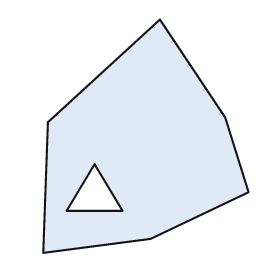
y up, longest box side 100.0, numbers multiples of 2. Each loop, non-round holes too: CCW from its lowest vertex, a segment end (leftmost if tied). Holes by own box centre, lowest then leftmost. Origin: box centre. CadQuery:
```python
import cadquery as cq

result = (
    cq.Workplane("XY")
    .moveTo(-44.0, -50.0)
    .lineTo(2.0, -44.0)
    .lineTo(44.0, -24.0)
    .lineTo(34.0, 8.0)
    .lineTo(6.0, 50.0)
    .lineTo(-42.0, 6.0)
    .close()
    .moveTo(-34.0, -32.0)
    .lineTo(-10.0, -32.0)
    .lineTo(-22.0, -12.0)
    .close()
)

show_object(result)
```